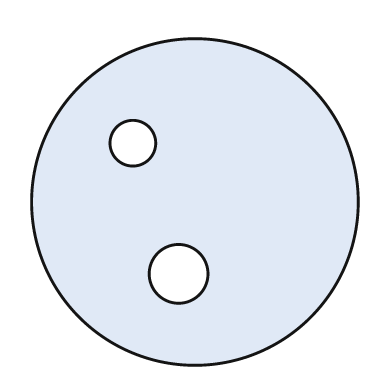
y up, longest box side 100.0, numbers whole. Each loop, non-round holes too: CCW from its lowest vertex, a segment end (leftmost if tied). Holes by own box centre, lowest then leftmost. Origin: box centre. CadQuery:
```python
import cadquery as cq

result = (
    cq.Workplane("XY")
    .moveTo(0.0, 0.0)
    .circle(50.0)
    .moveTo(-5.0, -22.0)
    .circle(9.0)
    .moveTo(-19.0, 18.0)
    .circle(7.0)
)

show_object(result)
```